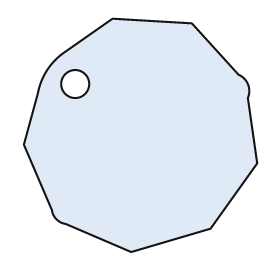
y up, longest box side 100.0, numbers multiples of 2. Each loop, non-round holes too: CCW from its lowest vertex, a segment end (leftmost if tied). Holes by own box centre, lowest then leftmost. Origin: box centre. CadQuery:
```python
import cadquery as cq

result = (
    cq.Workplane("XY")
    .moveTo(-4.0, -50.0)
    .lineTo(30.0, -40.0)
    .lineTo(50.0, -12.0)
    .lineTo(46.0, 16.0)
    .threePointArc((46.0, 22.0), (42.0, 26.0))
    .lineTo(22.0, 48.0)
    .lineTo(-12.0, 50.0)
    .lineTo(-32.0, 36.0)
    .threePointArc((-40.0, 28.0), (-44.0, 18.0))
    .lineTo(-50.0, -4.0)
    .lineTo(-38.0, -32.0)
    .threePointArc((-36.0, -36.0), (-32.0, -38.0))
    .close()
    .moveTo(-28.0, 22.0)
    .circle(6.0)
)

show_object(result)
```